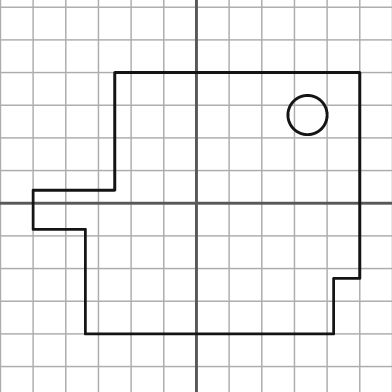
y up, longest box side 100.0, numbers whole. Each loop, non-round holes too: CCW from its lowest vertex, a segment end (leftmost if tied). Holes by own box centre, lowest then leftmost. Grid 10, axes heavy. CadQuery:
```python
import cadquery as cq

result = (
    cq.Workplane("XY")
    .moveTo(-34.0, -40.0)
    .lineTo(42.0, -40.0)
    .lineTo(42.0, -23.0)
    .lineTo(50.0, -23.0)
    .lineTo(50.0, 40.0)
    .lineTo(-25.0, 40.0)
    .lineTo(-25.0, 4.0)
    .lineTo(-50.0, 4.0)
    .lineTo(-50.0, -8.0)
    .lineTo(-34.0, -8.0)
    .close()
    .moveTo(34.0, 27.0)
    .circle(6.0)
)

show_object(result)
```